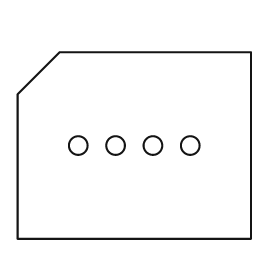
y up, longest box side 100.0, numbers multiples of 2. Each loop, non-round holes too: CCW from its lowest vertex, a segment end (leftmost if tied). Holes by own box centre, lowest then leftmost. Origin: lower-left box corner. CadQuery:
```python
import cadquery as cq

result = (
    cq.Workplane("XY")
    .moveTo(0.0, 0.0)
    .lineTo(100.0, 0.0)
    .lineTo(100.0, 80.0)
    .lineTo(18.0, 80.0)
    .lineTo(0.0, 62.0)
    .close()
    .moveTo(26.0, 40.0)
    .circle(4.0)
    .moveTo(42.0, 40.0)
    .circle(4.0)
    .moveTo(58.0, 40.0)
    .circle(4.0)
    .moveTo(74.0, 40.0)
    .circle(4.0)
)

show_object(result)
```